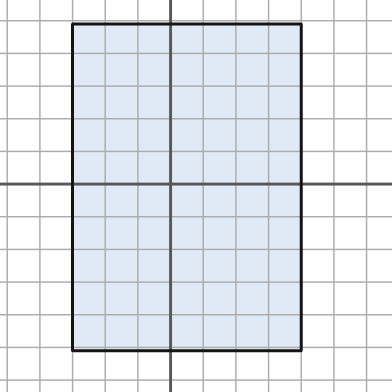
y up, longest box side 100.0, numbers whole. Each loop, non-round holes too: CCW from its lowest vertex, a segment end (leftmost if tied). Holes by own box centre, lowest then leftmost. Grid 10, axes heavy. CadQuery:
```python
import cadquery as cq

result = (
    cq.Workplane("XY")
    .moveTo(-30.0, -51.0)
    .lineTo(40.0, -51.0)
    .lineTo(40.0, 49.0)
    .lineTo(-30.0, 49.0)
    .close()
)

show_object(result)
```